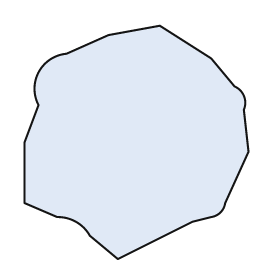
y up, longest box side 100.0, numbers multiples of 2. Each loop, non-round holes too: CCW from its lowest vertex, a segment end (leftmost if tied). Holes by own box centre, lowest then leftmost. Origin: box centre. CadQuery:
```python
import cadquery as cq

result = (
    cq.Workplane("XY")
    .moveTo(-8.0, -50.0)
    .lineTo(24.0, -34.0)
    .lineTo(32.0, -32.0)
    .threePointArc((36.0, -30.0), (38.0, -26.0))
    .lineTo(48.0, -4.0)
    .lineTo(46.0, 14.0)
    .threePointArc((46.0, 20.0), (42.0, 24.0))
    .lineTo(32.0, 36.0)
    .lineTo(10.0, 50.0)
    .lineTo(-12.0, 46.0)
    .lineTo(-30.0, 38.0)
    .threePointArc((-42.0, 30.0), (-42.0, 16.0))
    .lineTo(-48.0, 0.0)
    .lineTo(-48.0, -26.0)
    .lineTo(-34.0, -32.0)
    .threePointArc((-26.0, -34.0), (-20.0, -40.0))
    .close()
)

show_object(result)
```